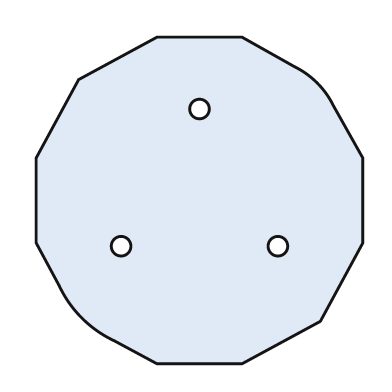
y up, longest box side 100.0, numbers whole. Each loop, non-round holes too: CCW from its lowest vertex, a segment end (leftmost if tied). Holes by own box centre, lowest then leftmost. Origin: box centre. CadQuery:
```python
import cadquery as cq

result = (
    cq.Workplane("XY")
    .moveTo(-13.0, -50.0)
    .lineTo(13.0, -50.0)
    .lineTo(37.0, -37.0)
    .lineTo(50.0, -13.0)
    .lineTo(50.0, 13.0)
    .lineTo(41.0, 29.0)
    .threePointArc((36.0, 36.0), (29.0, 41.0))
    .lineTo(13.0, 50.0)
    .lineTo(-13.0, 50.0)
    .lineTo(-37.0, 37.0)
    .lineTo(-50.0, 13.0)
    .lineTo(-50.0, -13.0)
    .lineTo(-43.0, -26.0)
    .threePointArc((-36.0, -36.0), (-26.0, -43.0))
    .close()
    .moveTo(-24.0, -14.0)
    .circle(3.0)
    .moveTo(24.0, -14.0)
    .circle(3.0)
    .moveTo(0.0, 28.0)
    .circle(3.0)
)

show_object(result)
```